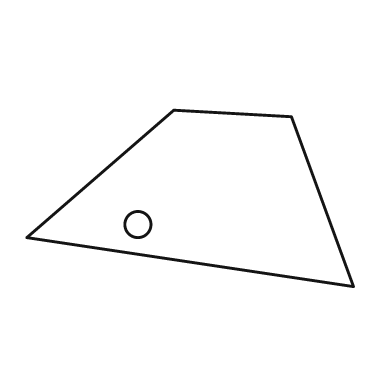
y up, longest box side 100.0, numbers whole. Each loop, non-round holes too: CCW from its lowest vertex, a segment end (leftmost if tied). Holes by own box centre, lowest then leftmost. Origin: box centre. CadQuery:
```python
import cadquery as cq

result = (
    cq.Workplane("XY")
    .moveTo(50.0, -27.0)
    .lineTo(31.0, 25.0)
    .lineTo(-5.0, 27.0)
    .lineTo(-50.0, -12.0)
    .close()
    .moveTo(-16.0, -8.0)
    .circle(4.0)
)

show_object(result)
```